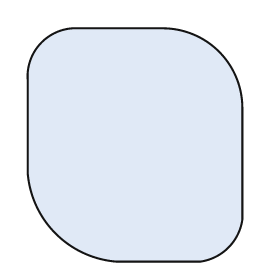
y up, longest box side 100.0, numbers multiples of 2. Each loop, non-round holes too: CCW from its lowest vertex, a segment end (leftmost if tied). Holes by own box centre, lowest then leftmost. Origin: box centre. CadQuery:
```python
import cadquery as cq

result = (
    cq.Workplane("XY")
    .moveTo(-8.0, -50.0)
    .lineTo(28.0, -50.0)
    .threePointArc((40.0, -44.0), (46.0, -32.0))
    .lineTo(46.0, 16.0)
    .threePointArc((36.0, 40.0), (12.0, 50.0))
    .lineTo(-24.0, 50.0)
    .threePointArc((-40.0, 44.0), (-46.0, 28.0))
    .lineTo(-46.0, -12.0)
    .threePointArc((-34.0, -38.0), (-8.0, -50.0))
    .close()
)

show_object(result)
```